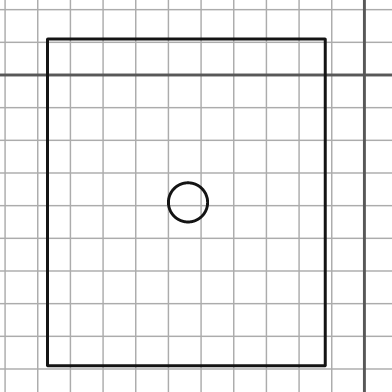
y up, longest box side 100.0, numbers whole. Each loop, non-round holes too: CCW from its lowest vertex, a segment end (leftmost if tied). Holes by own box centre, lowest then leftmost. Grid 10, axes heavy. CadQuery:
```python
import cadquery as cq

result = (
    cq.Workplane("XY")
    .moveTo(-97.0, -89.0)
    .lineTo(-12.0, -89.0)
    .lineTo(-12.0, 11.0)
    .lineTo(-97.0, 11.0)
    .close()
    .moveTo(-54.0, -39.0)
    .circle(6.0)
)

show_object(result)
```